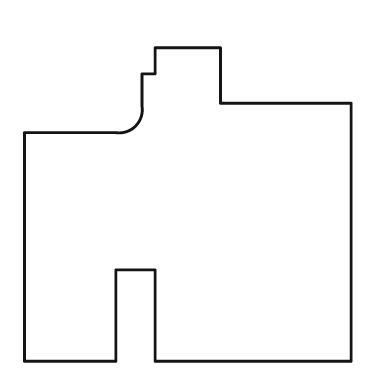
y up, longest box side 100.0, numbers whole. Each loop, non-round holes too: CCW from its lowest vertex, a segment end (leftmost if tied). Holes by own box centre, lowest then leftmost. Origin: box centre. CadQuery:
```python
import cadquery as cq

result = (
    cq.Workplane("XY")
    .moveTo(-50.0, -48.0)
    .lineTo(-22.0, -48.0)
    .lineTo(-22.0, -20.0)
    .lineTo(-10.0, -20.0)
    .lineTo(-10.0, -48.0)
    .lineTo(50.0, -48.0)
    .lineTo(50.0, 31.0)
    .lineTo(10.0, 31.0)
    .lineTo(10.0, 48.0)
    .lineTo(-10.0, 48.0)
    .lineTo(-10.0, 40.0)
    .lineTo(-14.0, 40.0)
    .lineTo(-14.0, 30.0)
    .threePointArc((-16.0, 24.0), (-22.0, 22.0))
    .lineTo(-50.0, 22.0)
    .close()
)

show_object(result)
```